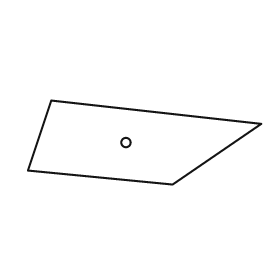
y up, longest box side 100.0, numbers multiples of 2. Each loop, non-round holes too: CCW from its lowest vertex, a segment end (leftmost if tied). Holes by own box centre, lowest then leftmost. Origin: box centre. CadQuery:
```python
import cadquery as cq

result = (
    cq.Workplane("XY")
    .moveTo(12.0, -18.0)
    .lineTo(50.0, 8.0)
    .lineTo(-40.0, 18.0)
    .lineTo(-50.0, -12.0)
    .close()
    .moveTo(-8.0, 0.0)
    .circle(2.0)
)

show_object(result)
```